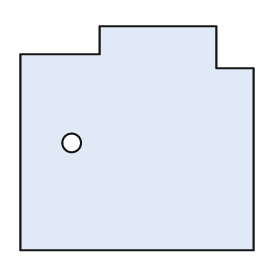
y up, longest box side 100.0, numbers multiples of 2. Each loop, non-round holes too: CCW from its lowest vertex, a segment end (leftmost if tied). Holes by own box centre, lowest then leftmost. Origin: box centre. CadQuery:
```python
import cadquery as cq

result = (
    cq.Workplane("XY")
    .moveTo(-50.0, -48.0)
    .lineTo(50.0, -48.0)
    .lineTo(50.0, 30.0)
    .lineTo(34.0, 30.0)
    .lineTo(34.0, 48.0)
    .lineTo(-16.0, 48.0)
    .lineTo(-16.0, 36.0)
    .lineTo(-50.0, 36.0)
    .close()
    .moveTo(-28.0, -2.0)
    .circle(4.0)
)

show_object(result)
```